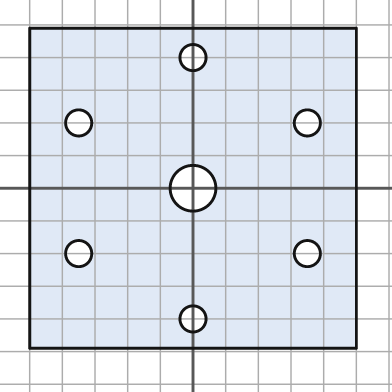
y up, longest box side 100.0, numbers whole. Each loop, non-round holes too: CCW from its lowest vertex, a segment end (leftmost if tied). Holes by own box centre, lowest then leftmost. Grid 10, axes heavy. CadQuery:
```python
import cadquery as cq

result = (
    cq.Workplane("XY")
    .moveTo(-50.0, -49.0)
    .lineTo(50.0, -49.0)
    .lineTo(50.0, 49.0)
    .lineTo(-50.0, 49.0)
    .close()
    .moveTo(0.0, -40.0)
    .circle(4.0)
    .moveTo(-35.0, -20.0)
    .circle(4.0)
    .moveTo(35.0, -20.0)
    .circle(4.0)
    .moveTo(0.0, 0.0)
    .circle(7.0)
    .moveTo(-35.0, 20.0)
    .circle(4.0)
    .moveTo(35.0, 20.0)
    .circle(4.0)
    .moveTo(0.0, 40.0)
    .circle(4.0)
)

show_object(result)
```